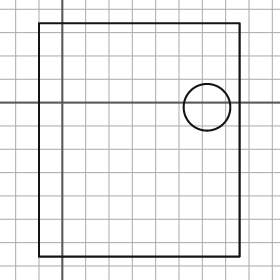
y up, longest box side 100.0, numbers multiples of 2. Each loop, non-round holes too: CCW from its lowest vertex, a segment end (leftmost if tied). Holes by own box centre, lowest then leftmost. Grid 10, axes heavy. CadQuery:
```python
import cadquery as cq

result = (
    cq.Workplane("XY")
    .moveTo(-10.0, -66.0)
    .lineTo(76.0, -66.0)
    .lineTo(76.0, 34.0)
    .lineTo(-10.0, 34.0)
    .close()
    .moveTo(62.0, -2.0)
    .circle(10.0)
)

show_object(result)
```